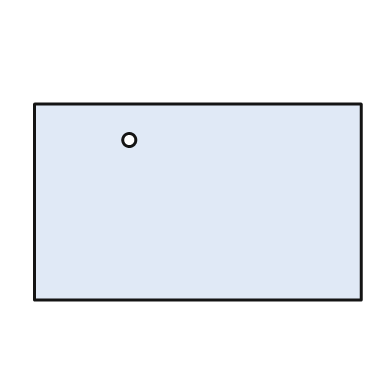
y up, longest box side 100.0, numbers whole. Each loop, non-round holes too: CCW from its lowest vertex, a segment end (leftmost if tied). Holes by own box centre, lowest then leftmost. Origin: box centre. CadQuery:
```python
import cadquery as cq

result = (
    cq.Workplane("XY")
    .moveTo(-50.0, -30.0)
    .lineTo(50.0, -30.0)
    .lineTo(50.0, 30.0)
    .lineTo(-50.0, 30.0)
    .close()
    .moveTo(-21.0, 19.0)
    .circle(2.0)
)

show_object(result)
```